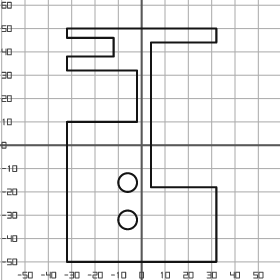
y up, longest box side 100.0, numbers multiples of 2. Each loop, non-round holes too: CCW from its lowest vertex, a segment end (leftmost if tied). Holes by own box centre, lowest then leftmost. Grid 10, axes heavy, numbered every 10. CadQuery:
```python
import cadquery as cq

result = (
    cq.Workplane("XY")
    .moveTo(-32.0, -50.0)
    .lineTo(32.0, -50.0)
    .lineTo(32.0, -18.0)
    .lineTo(4.0, -18.0)
    .lineTo(4.0, 44.0)
    .lineTo(32.0, 44.0)
    .lineTo(32.0, 50.0)
    .lineTo(-32.0, 50.0)
    .lineTo(-32.0, 46.0)
    .lineTo(-12.0, 46.0)
    .lineTo(-12.0, 38.0)
    .lineTo(-32.0, 38.0)
    .lineTo(-32.0, 32.0)
    .lineTo(-2.0, 32.0)
    .lineTo(-2.0, 10.0)
    .lineTo(-32.0, 10.0)
    .close()
    .moveTo(-6.0, -32.0)
    .circle(4.0)
    .moveTo(-6.0, -16.0)
    .circle(4.0)
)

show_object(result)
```